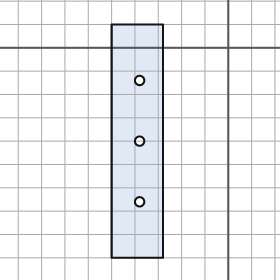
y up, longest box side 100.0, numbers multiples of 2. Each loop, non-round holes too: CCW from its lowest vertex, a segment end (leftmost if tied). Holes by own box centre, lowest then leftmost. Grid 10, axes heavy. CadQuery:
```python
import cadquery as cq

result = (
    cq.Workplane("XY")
    .moveTo(-50.0, -90.0)
    .lineTo(-28.0, -90.0)
    .lineTo(-28.0, 10.0)
    .lineTo(-50.0, 10.0)
    .close()
    .moveTo(-38.0, -66.0)
    .circle(2.0)
    .moveTo(-38.0, -40.0)
    .circle(2.0)
    .moveTo(-38.0, -14.0)
    .circle(2.0)
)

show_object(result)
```